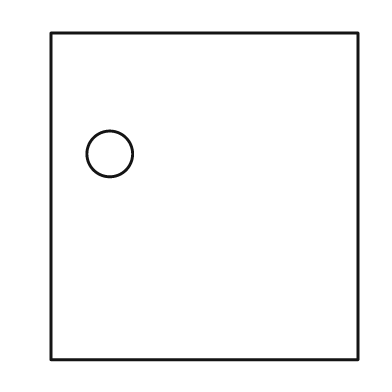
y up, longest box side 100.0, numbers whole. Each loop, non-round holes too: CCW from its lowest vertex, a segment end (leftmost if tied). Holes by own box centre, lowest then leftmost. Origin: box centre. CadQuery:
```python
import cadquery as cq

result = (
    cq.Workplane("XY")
    .moveTo(-47.0, -50.0)
    .lineTo(47.0, -50.0)
    .lineTo(47.0, 50.0)
    .lineTo(-47.0, 50.0)
    .close()
    .moveTo(-29.0, 13.0)
    .circle(7.0)
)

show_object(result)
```